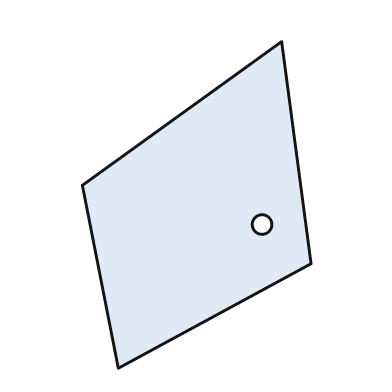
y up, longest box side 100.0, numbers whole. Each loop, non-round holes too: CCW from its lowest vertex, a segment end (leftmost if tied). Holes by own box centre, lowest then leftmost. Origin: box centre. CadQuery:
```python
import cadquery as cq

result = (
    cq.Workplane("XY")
    .moveTo(-24.0, -50.0)
    .lineTo(35.0, -18.0)
    .lineTo(26.0, 50.0)
    .lineTo(-35.0, 6.0)
    .close()
    .moveTo(20.0, -6.0)
    .circle(3.0)
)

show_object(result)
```